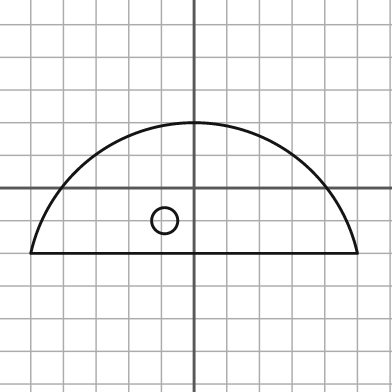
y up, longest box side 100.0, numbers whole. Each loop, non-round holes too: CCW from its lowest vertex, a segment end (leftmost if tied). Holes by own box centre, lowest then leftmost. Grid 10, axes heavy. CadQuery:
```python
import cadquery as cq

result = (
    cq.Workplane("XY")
    .moveTo(-50.0, -20.0)
    .lineTo(50.0, -20.0)
    .threePointArc((0.0, 20.0), (-50.0, -20.0))
    .close()
    .moveTo(-9.0, -10.0)
    .circle(4.0)
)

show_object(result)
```